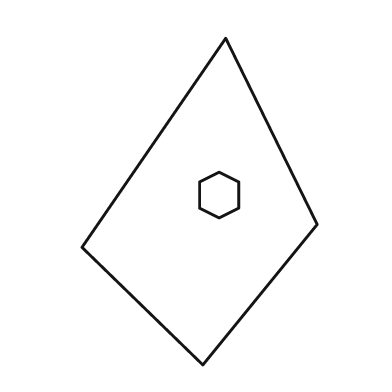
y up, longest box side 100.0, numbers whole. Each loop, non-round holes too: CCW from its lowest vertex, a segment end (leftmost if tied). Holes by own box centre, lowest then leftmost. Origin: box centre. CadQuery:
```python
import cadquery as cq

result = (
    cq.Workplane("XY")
    .moveTo(1.0, -50.0)
    .lineTo(36.0, -7.0)
    .lineTo(8.0, 50.0)
    .lineTo(-36.0, -14.0)
    .close()
    .moveTo(6.0, -5.0)
    .lineTo(12.0, -2.0)
    .lineTo(12.0, 6.0)
    .lineTo(6.0, 9.0)
    .lineTo(0.0, 6.0)
    .lineTo(0.0, -2.0)
    .close()
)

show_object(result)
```